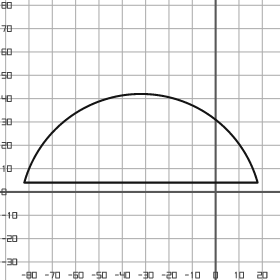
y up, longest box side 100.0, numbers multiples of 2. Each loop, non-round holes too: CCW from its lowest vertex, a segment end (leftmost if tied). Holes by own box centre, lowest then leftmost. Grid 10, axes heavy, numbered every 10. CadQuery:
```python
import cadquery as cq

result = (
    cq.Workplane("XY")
    .moveTo(-82.0, 4.0)
    .lineTo(18.0, 4.0)
    .threePointArc((-32.0, 42.0), (-82.0, 4.0))
    .close()
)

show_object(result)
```